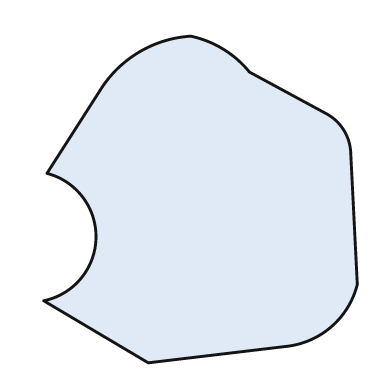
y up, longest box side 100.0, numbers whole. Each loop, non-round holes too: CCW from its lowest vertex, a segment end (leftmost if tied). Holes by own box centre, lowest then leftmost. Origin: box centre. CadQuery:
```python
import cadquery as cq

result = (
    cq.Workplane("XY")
    .moveTo(-16.0, -50.0)
    .lineTo(26.0, -45.0)
    .threePointArc((40.0, -39.0), (48.0, -26.0))
    .lineTo(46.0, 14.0)
    .threePointArc((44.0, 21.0), (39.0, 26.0))
    .lineTo(15.0, 39.0)
    .threePointArc((7.0, 46.0), (-3.0, 50.0))
    .threePointArc((-19.0, 45.0), (-31.0, 33.0))
    .lineTo(-47.0, 8.0)
    .threePointArc((-32.0, -12.0), (-48.0, -31.0))
    .close()
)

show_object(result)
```